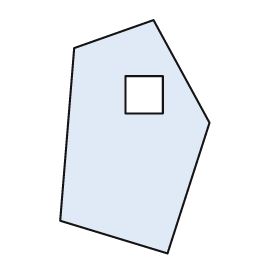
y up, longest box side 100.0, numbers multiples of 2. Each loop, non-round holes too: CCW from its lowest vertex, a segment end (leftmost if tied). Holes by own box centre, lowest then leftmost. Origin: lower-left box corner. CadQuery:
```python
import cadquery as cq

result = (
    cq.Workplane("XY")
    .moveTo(46.0, 0.0)
    .lineTo(64.0, 56.0)
    .lineTo(40.0, 100.0)
    .lineTo(6.0, 88.0)
    .lineTo(0.0, 14.0)
    .close()
    .moveTo(28.0, 60.0)
    .lineTo(44.0, 60.0)
    .lineTo(44.0, 76.0)
    .lineTo(28.0, 76.0)
    .close()
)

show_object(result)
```